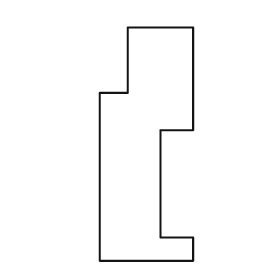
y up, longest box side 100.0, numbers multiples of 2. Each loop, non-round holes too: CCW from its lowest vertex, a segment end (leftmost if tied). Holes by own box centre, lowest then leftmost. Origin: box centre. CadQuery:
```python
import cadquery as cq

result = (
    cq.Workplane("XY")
    .moveTo(-20.0, -50.0)
    .lineTo(20.0, -50.0)
    .lineTo(20.0, -40.0)
    .lineTo(6.0, -40.0)
    .lineTo(6.0, 6.0)
    .lineTo(20.0, 6.0)
    .lineTo(20.0, 50.0)
    .lineTo(-8.0, 50.0)
    .lineTo(-8.0, 22.0)
    .lineTo(-20.0, 22.0)
    .close()
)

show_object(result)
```